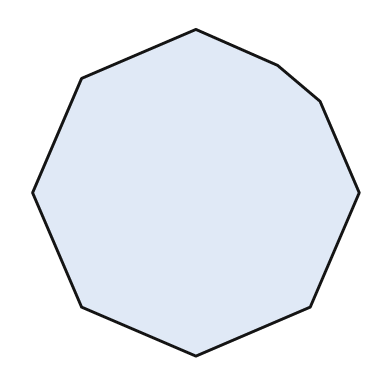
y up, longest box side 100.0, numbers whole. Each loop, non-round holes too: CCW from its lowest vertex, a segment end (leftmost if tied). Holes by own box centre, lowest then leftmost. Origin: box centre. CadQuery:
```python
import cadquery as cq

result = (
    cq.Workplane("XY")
    .moveTo(0.0, -50.0)
    .lineTo(35.0, -35.0)
    .lineTo(50.0, 0.0)
    .lineTo(38.0, 28.0)
    .lineTo(25.0, 39.0)
    .lineTo(0.0, 50.0)
    .lineTo(-35.0, 35.0)
    .lineTo(-50.0, 0.0)
    .lineTo(-35.0, -35.0)
    .close()
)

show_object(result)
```